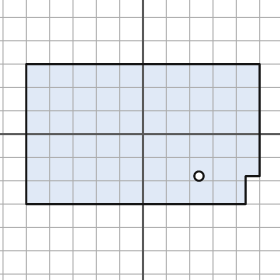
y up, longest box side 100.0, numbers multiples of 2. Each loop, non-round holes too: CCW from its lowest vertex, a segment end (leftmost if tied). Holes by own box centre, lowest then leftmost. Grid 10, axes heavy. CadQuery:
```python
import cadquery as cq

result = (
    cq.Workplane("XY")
    .moveTo(-50.0, -30.0)
    .lineTo(44.0, -30.0)
    .lineTo(44.0, -18.0)
    .lineTo(50.0, -18.0)
    .lineTo(50.0, 30.0)
    .lineTo(-50.0, 30.0)
    .close()
    .moveTo(24.0, -18.0)
    .circle(2.0)
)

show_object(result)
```